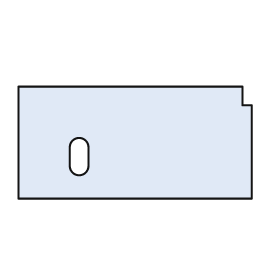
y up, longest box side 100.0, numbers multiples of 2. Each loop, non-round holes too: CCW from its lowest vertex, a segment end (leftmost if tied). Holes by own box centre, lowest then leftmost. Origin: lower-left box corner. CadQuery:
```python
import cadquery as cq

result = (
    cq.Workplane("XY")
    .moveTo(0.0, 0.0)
    .lineTo(100.0, 0.0)
    .lineTo(100.0, 40.0)
    .lineTo(96.0, 40.0)
    .lineTo(96.0, 48.0)
    .lineTo(0.0, 48.0)
    .close()
    .moveTo(22.0, 14.0)
    .threePointArc((26.0, 10.0), (30.0, 14.0))
    .lineTo(30.0, 22.0)
    .threePointArc((26.0, 26.0), (22.0, 22.0))
    .close()
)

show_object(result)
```